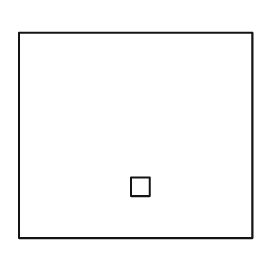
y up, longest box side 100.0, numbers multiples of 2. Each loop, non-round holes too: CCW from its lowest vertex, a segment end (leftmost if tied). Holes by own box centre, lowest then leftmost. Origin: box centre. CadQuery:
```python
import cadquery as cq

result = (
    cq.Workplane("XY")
    .moveTo(-50.0, -44.0)
    .lineTo(50.0, -44.0)
    .lineTo(50.0, 44.0)
    .lineTo(-50.0, 44.0)
    .close()
    .moveTo(-2.0, -26.0)
    .lineTo(6.0, -26.0)
    .lineTo(6.0, -18.0)
    .lineTo(-2.0, -18.0)
    .close()
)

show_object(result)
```